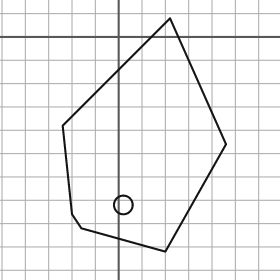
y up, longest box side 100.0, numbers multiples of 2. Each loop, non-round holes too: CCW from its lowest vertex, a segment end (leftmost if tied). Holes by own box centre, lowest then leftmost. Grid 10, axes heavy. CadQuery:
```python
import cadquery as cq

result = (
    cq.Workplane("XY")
    .moveTo(20.0, -92.0)
    .lineTo(46.0, -46.0)
    .lineTo(22.0, 8.0)
    .lineTo(-24.0, -38.0)
    .lineTo(-20.0, -76.0)
    .lineTo(-16.0, -82.0)
    .close()
    .moveTo(2.0, -72.0)
    .circle(4.0)
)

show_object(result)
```